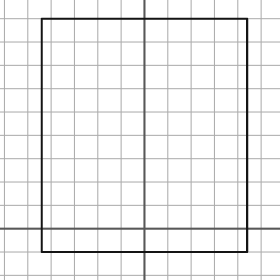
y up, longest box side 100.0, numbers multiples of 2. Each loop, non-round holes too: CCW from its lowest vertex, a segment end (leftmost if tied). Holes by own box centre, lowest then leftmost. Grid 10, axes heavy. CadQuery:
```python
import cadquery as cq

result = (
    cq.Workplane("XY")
    .moveTo(-44.0, -10.0)
    .lineTo(44.0, -10.0)
    .lineTo(44.0, 90.0)
    .lineTo(-44.0, 90.0)
    .close()
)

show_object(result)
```